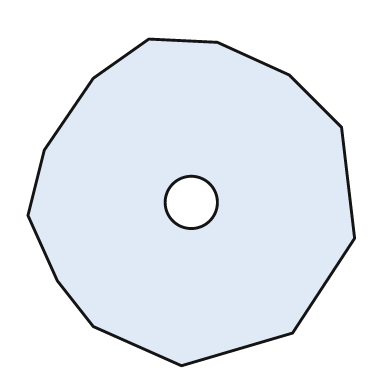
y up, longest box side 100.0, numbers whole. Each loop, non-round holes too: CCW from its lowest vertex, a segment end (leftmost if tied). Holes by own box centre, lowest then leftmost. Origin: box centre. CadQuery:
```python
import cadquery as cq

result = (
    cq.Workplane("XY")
    .moveTo(-3.0, -50.0)
    .lineTo(31.0, -40.0)
    .lineTo(50.0, -11.0)
    .lineTo(46.0, 23.0)
    .lineTo(30.0, 39.0)
    .lineTo(8.0, 49.0)
    .lineTo(-13.0, 50.0)
    .lineTo(-30.0, 38.0)
    .lineTo(-45.0, 16.0)
    .lineTo(-50.0, -4.0)
    .lineTo(-41.0, -24.0)
    .lineTo(-30.0, -38.0)
    .close()
    .moveTo(0.0, 0.0)
    .circle(8.0)
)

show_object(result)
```